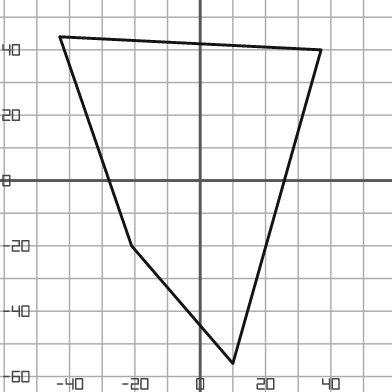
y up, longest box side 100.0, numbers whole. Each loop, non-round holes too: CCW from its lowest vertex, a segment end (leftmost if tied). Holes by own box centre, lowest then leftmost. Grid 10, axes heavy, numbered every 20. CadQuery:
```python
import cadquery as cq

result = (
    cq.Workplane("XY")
    .moveTo(10.0, -56.0)
    .lineTo(37.0, 40.0)
    .lineTo(-43.0, 44.0)
    .lineTo(-21.0, -20.0)
    .close()
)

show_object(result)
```